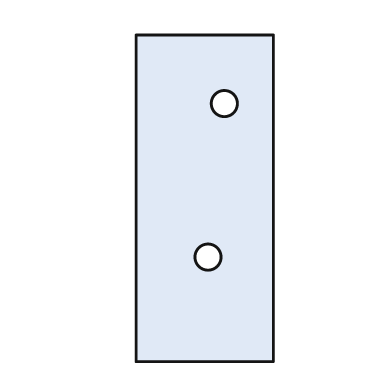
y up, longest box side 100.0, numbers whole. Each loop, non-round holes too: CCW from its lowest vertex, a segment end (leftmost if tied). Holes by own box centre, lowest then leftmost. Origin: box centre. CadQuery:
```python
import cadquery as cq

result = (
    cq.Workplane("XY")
    .moveTo(-21.0, -50.0)
    .lineTo(21.0, -50.0)
    .lineTo(21.0, 50.0)
    .lineTo(-21.0, 50.0)
    .close()
    .moveTo(1.0, -18.0)
    .circle(4.0)
    .moveTo(6.0, 29.0)
    .circle(4.0)
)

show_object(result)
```